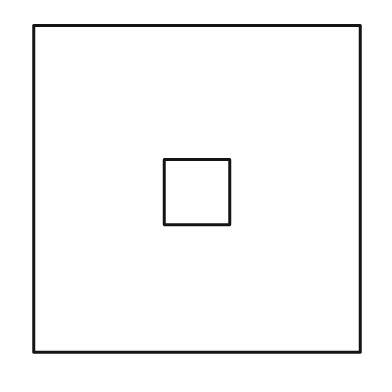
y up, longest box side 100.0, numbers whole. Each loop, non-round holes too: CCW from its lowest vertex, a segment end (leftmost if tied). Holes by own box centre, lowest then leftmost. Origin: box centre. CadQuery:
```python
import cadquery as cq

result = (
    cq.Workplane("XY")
    .moveTo(-50.0, -50.0)
    .lineTo(50.0, -50.0)
    .lineTo(50.0, 50.0)
    .lineTo(-50.0, 50.0)
    .close()
    .moveTo(-10.0, -11.0)
    .lineTo(10.0, -11.0)
    .lineTo(10.0, 9.0)
    .lineTo(-10.0, 9.0)
    .close()
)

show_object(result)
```